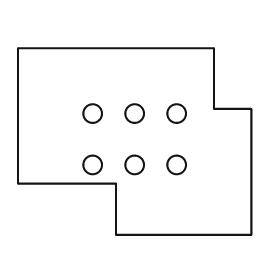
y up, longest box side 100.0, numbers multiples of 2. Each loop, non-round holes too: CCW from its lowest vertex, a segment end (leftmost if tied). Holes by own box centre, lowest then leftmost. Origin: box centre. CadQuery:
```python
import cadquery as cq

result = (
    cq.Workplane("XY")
    .moveTo(-8.0, -40.0)
    .lineTo(50.0, -40.0)
    .lineTo(50.0, 14.0)
    .lineTo(34.0, 14.0)
    .lineTo(34.0, 40.0)
    .lineTo(-50.0, 40.0)
    .lineTo(-50.0, -18.0)
    .lineTo(-8.0, -18.0)
    .close()
    .moveTo(-18.0, -10.0)
    .circle(4.0)
    .moveTo(0.0, -10.0)
    .circle(4.0)
    .moveTo(18.0, -10.0)
    .circle(4.0)
    .moveTo(-18.0, 12.0)
    .circle(4.0)
    .moveTo(0.0, 12.0)
    .circle(4.0)
    .moveTo(18.0, 12.0)
    .circle(4.0)
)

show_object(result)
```